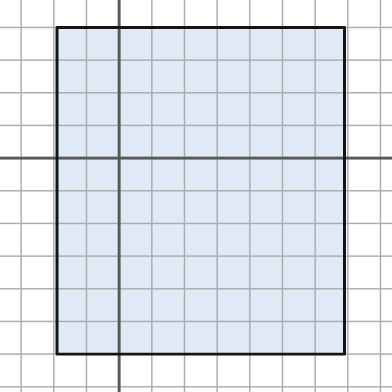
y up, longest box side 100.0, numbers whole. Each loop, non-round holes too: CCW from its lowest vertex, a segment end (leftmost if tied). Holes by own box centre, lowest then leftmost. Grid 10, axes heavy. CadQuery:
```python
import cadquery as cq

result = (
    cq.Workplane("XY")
    .moveTo(-19.0, -60.0)
    .lineTo(69.0, -60.0)
    .lineTo(69.0, 40.0)
    .lineTo(-19.0, 40.0)
    .close()
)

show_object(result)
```